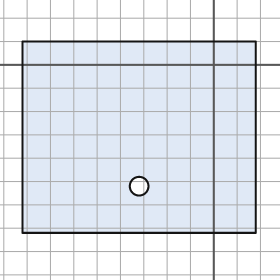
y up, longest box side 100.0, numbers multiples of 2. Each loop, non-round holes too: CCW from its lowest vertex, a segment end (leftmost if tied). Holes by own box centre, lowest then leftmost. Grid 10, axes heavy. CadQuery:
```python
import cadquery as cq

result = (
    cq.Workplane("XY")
    .moveTo(-82.0, -72.0)
    .lineTo(18.0, -72.0)
    .lineTo(18.0, 10.0)
    .lineTo(-82.0, 10.0)
    .close()
    .moveTo(-32.0, -52.0)
    .circle(4.0)
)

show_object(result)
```